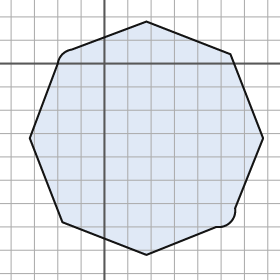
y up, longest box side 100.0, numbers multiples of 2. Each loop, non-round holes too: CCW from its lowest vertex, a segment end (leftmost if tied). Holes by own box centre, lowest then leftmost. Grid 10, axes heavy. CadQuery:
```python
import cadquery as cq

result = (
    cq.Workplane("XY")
    .moveTo(18.0, -82.0)
    .lineTo(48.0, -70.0)
    .threePointArc((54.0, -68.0), (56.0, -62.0))
    .lineTo(68.0, -32.0)
    .lineTo(54.0, 4.0)
    .lineTo(18.0, 18.0)
    .lineTo(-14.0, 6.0)
    .threePointArc((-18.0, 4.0), (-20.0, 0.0))
    .lineTo(-32.0, -32.0)
    .lineTo(-18.0, -68.0)
    .close()
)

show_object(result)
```